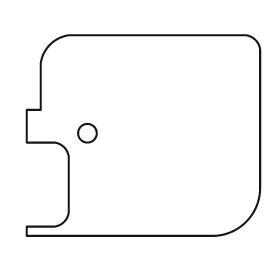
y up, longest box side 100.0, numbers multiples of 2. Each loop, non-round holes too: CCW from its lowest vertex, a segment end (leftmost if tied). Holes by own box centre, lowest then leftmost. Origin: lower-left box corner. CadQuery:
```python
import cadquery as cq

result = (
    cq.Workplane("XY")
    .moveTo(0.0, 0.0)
    .lineTo(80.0, 0.0)
    .threePointArc((94.0, 6.0), (100.0, 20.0))
    .lineTo(100.0, 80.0)
    .threePointArc((98.0, 84.0), (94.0, 86.0))
    .lineTo(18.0, 86.0)
    .threePointArc((10.0, 82.0), (6.0, 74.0))
    .lineTo(6.0, 54.0)
    .lineTo(0.0, 54.0)
    .lineTo(0.0, 40.0)
    .lineTo(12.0, 40.0)
    .threePointArc((16.0, 38.0), (18.0, 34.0))
    .lineTo(18.0, 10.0)
    .threePointArc((16.0, 6.0), (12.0, 4.0))
    .lineTo(0.0, 4.0)
    .close()
    .moveTo(26.0, 44.0)
    .circle(4.0)
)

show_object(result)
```